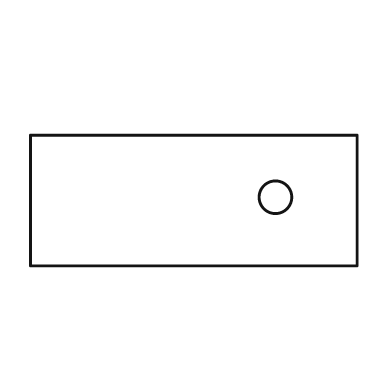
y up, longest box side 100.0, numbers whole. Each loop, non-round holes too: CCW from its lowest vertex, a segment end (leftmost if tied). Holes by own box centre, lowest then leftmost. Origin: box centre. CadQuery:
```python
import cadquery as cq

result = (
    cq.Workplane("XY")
    .moveTo(-50.0, -20.0)
    .lineTo(50.0, -20.0)
    .lineTo(50.0, 20.0)
    .lineTo(-50.0, 20.0)
    .close()
    .moveTo(25.0, 1.0)
    .circle(5.0)
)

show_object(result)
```